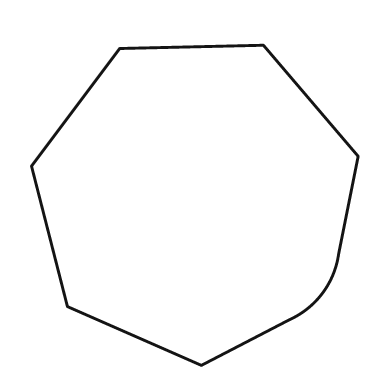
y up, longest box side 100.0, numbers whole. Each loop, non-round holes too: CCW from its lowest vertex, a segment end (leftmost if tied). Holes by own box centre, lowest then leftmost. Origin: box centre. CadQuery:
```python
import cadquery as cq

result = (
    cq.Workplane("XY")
    .moveTo(2.0, -49.0)
    .lineTo(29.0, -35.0)
    .threePointArc((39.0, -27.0), (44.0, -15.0))
    .lineTo(50.0, 15.0)
    .lineTo(21.0, 49.0)
    .lineTo(-23.0, 48.0)
    .lineTo(-50.0, 12.0)
    .lineTo(-39.0, -31.0)
    .close()
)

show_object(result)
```